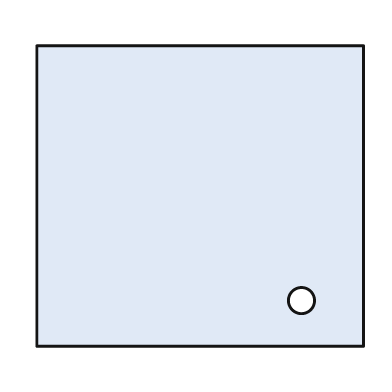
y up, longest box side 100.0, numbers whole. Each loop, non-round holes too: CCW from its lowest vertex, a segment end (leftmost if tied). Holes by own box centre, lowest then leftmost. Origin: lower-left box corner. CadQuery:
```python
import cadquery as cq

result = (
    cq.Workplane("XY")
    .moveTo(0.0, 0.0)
    .lineTo(100.0, 0.0)
    .lineTo(100.0, 92.0)
    .lineTo(0.0, 92.0)
    .close()
    .moveTo(81.0, 14.0)
    .circle(4.0)
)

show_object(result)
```